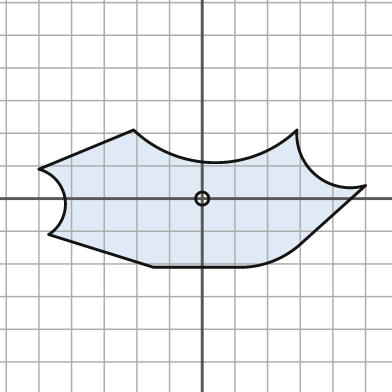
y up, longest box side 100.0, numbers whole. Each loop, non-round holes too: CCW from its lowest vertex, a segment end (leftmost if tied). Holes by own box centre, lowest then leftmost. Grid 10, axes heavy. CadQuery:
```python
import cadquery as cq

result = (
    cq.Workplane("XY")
    .moveTo(-15.0, -21.0)
    .lineTo(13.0, -21.0)
    .threePointArc((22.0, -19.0), (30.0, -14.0))
    .lineTo(50.0, 4.0)
    .threePointArc((35.0, 7.0), (29.0, 21.0))
    .threePointArc((4.0, 11.0), (-21.0, 21.0))
    .lineTo(-50.0, 9.0)
    .threePointArc((-42.0, 0.0), (-47.0, -11.0))
    .close()
    .moveTo(0.0, 0.0)
    .circle(2.0)
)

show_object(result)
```